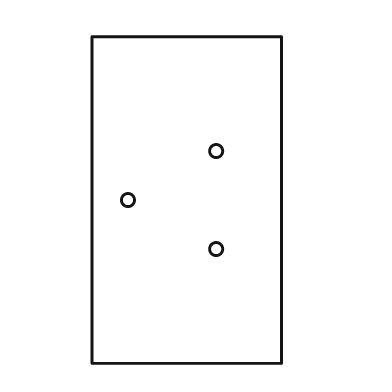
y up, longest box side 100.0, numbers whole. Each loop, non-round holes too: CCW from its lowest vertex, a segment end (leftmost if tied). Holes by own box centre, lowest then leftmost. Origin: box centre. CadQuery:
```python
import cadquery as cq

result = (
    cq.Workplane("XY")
    .moveTo(-29.0, -50.0)
    .lineTo(29.0, -50.0)
    .lineTo(29.0, 50.0)
    .lineTo(-29.0, 50.0)
    .close()
    .moveTo(9.0, -15.0)
    .circle(2.0)
    .moveTo(-18.0, 0.0)
    .circle(2.0)
    .moveTo(9.0, 15.0)
    .circle(2.0)
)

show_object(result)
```